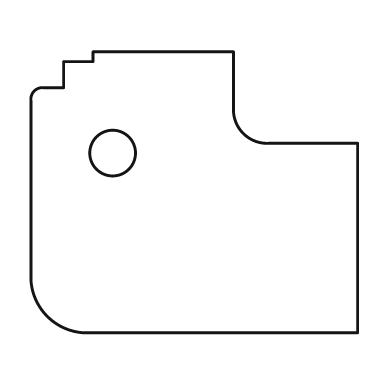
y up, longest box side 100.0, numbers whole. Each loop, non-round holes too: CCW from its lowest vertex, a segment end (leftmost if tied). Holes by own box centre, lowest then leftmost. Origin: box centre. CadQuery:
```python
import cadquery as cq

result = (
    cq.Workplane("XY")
    .moveTo(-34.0, -43.0)
    .lineTo(50.0, -43.0)
    .lineTo(50.0, 15.0)
    .lineTo(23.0, 15.0)
    .threePointArc((15.0, 18.0), (12.0, 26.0))
    .lineTo(12.0, 43.0)
    .lineTo(-31.0, 43.0)
    .lineTo(-31.0, 40.0)
    .lineTo(-40.0, 40.0)
    .lineTo(-40.0, 32.0)
    .lineTo(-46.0, 32.0)
    .threePointArc((-49.0, 31.0), (-50.0, 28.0))
    .lineTo(-50.0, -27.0)
    .threePointArc((-45.0, -38.0), (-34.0, -43.0))
    .close()
    .moveTo(-25.0, 12.0)
    .circle(7.0)
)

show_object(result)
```